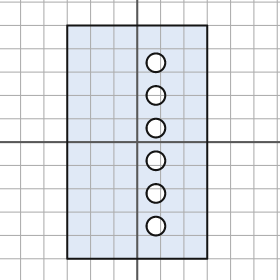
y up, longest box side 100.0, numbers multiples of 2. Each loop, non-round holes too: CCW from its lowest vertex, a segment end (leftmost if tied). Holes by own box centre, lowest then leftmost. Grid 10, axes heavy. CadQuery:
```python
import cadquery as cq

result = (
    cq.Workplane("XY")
    .moveTo(-30.0, -50.0)
    .lineTo(30.0, -50.0)
    .lineTo(30.0, 50.0)
    .lineTo(-30.0, 50.0)
    .close()
    .moveTo(8.0, -36.0)
    .circle(4.0)
    .moveTo(8.0, -22.0)
    .circle(4.0)
    .moveTo(8.0, -8.0)
    .circle(4.0)
    .moveTo(8.0, 6.0)
    .circle(4.0)
    .moveTo(8.0, 20.0)
    .circle(4.0)
    .moveTo(8.0, 34.0)
    .circle(4.0)
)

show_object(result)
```